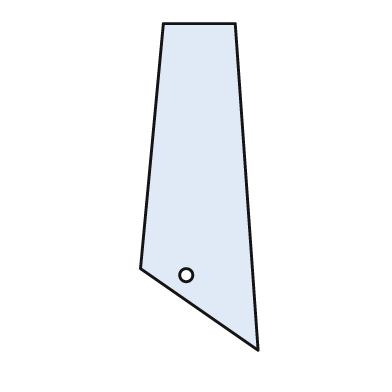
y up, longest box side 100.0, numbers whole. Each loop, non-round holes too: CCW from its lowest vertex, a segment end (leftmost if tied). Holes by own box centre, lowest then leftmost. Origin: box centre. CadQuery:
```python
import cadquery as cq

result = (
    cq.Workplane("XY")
    .moveTo(18.0, -50.0)
    .lineTo(11.0, 50.0)
    .lineTo(-11.0, 50.0)
    .lineTo(-18.0, -25.0)
    .close()
    .moveTo(-4.0, -27.0)
    .circle(2.0)
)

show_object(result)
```